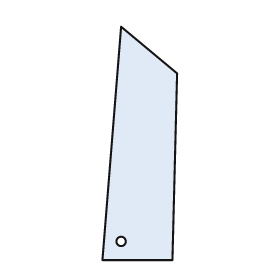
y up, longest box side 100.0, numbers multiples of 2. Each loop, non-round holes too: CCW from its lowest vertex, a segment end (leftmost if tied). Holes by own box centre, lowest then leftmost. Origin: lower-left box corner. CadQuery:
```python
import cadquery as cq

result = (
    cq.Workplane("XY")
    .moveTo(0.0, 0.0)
    .lineTo(30.0, 0.0)
    .lineTo(32.0, 80.0)
    .lineTo(8.0, 100.0)
    .close()
    .moveTo(8.0, 8.0)
    .circle(2.0)
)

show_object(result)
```